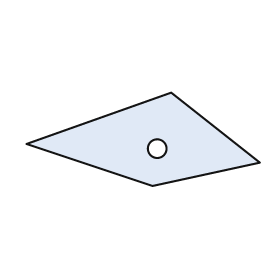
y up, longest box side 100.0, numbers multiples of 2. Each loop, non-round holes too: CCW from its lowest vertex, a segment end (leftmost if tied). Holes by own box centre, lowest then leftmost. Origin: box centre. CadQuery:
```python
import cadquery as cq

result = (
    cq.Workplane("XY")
    .moveTo(4.0, -20.0)
    .lineTo(50.0, -10.0)
    .lineTo(12.0, 20.0)
    .lineTo(-50.0, -2.0)
    .close()
    .moveTo(6.0, -4.0)
    .circle(4.0)
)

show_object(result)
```